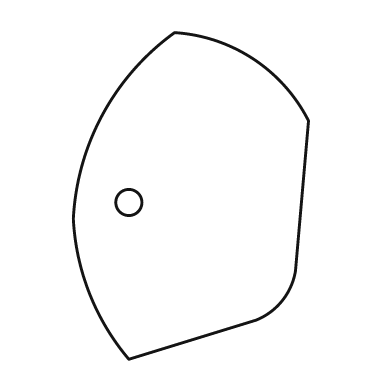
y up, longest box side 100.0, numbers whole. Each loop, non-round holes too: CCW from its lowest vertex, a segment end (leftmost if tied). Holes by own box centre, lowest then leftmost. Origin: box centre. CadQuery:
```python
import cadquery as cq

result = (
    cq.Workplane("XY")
    .moveTo(-19.0, -50.0)
    .lineTo(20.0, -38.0)
    .threePointArc((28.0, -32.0), (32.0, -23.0))
    .lineTo(36.0, 23.0)
    .threePointArc((19.0, 42.0), (-5.0, 50.0))
    .threePointArc((-27.0, 25.0), (-36.0, -7.0))
    .threePointArc((-31.0, -30.0), (-19.0, -50.0))
    .close()
    .moveTo(-19.0, -2.0)
    .circle(4.0)
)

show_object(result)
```